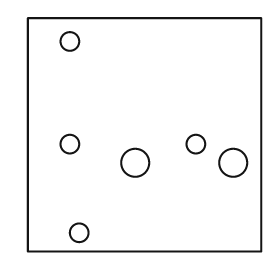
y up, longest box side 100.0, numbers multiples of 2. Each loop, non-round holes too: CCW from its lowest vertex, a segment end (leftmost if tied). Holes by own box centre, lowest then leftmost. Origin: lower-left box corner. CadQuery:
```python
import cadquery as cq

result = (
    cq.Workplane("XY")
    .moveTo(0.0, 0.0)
    .lineTo(100.0, 0.0)
    .lineTo(100.0, 100.0)
    .lineTo(0.0, 100.0)
    .close()
    .moveTo(22.0, 8.0)
    .circle(4.0)
    .moveTo(46.0, 38.0)
    .circle(6.0)
    .moveTo(88.0, 38.0)
    .circle(6.0)
    .moveTo(18.0, 46.0)
    .circle(4.0)
    .moveTo(72.0, 46.0)
    .circle(4.0)
    .moveTo(18.0, 90.0)
    .circle(4.0)
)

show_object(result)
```